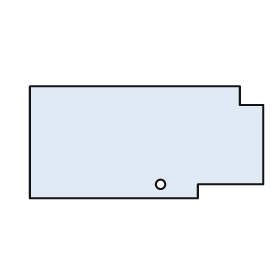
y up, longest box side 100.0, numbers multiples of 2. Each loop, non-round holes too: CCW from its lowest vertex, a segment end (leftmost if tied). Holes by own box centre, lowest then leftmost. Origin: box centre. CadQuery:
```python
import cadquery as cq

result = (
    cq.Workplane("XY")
    .moveTo(-50.0, -24.0)
    .lineTo(22.0, -24.0)
    .lineTo(22.0, -18.0)
    .lineTo(50.0, -18.0)
    .lineTo(50.0, 16.0)
    .lineTo(40.0, 16.0)
    .lineTo(40.0, 24.0)
    .lineTo(-50.0, 24.0)
    .close()
    .moveTo(6.0, -18.0)
    .circle(2.0)
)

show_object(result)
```